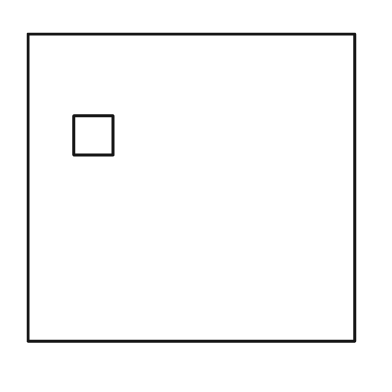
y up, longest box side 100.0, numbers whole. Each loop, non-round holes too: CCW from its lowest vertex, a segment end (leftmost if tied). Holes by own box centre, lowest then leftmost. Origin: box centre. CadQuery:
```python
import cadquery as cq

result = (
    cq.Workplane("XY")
    .moveTo(-50.0, -47.0)
    .lineTo(50.0, -47.0)
    .lineTo(50.0, 47.0)
    .lineTo(-50.0, 47.0)
    .close()
    .moveTo(-36.0, 10.0)
    .lineTo(-24.0, 10.0)
    .lineTo(-24.0, 22.0)
    .lineTo(-36.0, 22.0)
    .close()
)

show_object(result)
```